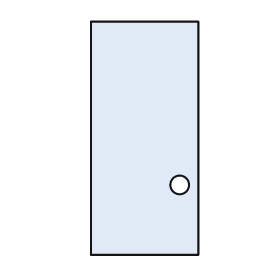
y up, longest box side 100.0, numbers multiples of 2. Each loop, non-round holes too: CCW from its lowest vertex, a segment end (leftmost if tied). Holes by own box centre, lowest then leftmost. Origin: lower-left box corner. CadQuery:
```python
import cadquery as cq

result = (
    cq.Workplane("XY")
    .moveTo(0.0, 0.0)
    .lineTo(46.0, 0.0)
    .lineTo(46.0, 100.0)
    .lineTo(0.0, 100.0)
    .close()
    .moveTo(38.0, 30.0)
    .circle(4.0)
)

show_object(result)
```